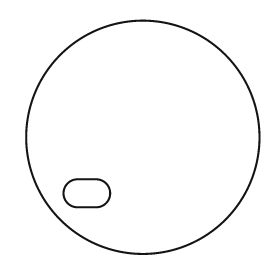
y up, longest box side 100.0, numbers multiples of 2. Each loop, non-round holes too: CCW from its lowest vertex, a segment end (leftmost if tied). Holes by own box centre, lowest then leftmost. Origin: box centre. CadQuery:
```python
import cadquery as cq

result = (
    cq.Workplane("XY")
    .moveTo(0.0, 0.0)
    .circle(50.0)
    .moveTo(-28.0, -30.0)
    .lineTo(-20.0, -30.0)
    .threePointArc((-14.0, -24.0), (-20.0, -18.0))
    .lineTo(-28.0, -18.0)
    .threePointArc((-34.0, -24.0), (-28.0, -30.0))
    .close()
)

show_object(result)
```